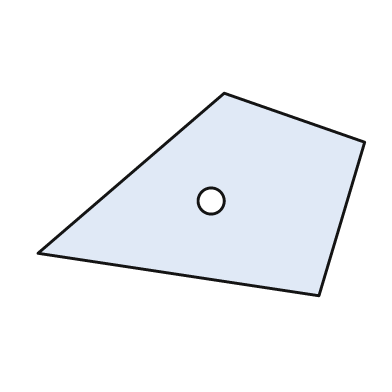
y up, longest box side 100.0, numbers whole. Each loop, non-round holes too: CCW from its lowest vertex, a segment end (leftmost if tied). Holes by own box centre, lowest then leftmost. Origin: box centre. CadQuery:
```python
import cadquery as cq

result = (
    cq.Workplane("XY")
    .moveTo(36.0, -31.0)
    .lineTo(50.0, 16.0)
    .lineTo(7.0, 31.0)
    .lineTo(-50.0, -18.0)
    .close()
    .moveTo(3.0, -2.0)
    .circle(4.0)
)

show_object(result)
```